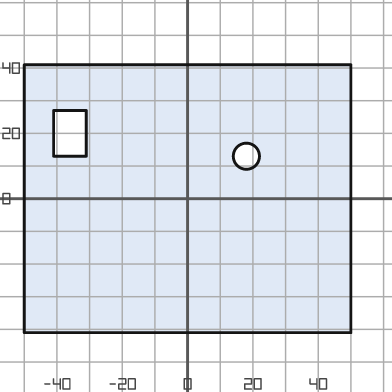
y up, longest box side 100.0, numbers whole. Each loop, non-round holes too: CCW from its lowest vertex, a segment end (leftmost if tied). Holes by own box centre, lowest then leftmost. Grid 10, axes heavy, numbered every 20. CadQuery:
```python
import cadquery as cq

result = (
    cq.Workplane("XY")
    .moveTo(-50.0, -41.0)
    .lineTo(50.0, -41.0)
    .lineTo(50.0, 41.0)
    .lineTo(-50.0, 41.0)
    .close()
    .moveTo(18.0, 13.0)
    .circle(4.0)
    .moveTo(-41.0, 13.0)
    .lineTo(-31.0, 13.0)
    .lineTo(-31.0, 27.0)
    .lineTo(-41.0, 27.0)
    .close()
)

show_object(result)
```